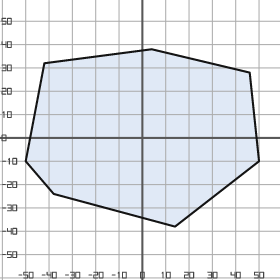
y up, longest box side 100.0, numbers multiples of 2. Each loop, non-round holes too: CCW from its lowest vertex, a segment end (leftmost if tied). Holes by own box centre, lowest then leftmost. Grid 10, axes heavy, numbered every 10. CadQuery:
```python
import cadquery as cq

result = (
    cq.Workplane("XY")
    .moveTo(14.0, -38.0)
    .lineTo(50.0, -10.0)
    .lineTo(46.0, 28.0)
    .lineTo(4.0, 38.0)
    .lineTo(-42.0, 32.0)
    .lineTo(-50.0, -10.0)
    .lineTo(-38.0, -24.0)
    .close()
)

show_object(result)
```